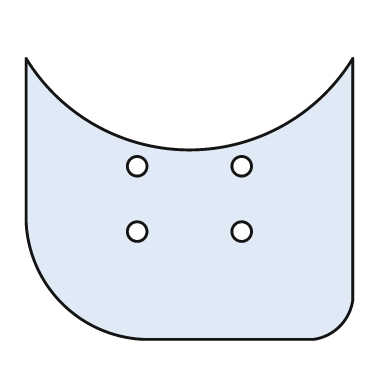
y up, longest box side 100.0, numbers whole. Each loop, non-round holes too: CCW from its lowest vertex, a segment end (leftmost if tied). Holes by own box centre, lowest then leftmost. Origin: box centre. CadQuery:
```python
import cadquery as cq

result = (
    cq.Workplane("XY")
    .moveTo(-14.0, -43.0)
    .lineTo(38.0, -43.0)
    .threePointArc((46.0, -39.0), (50.0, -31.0))
    .lineTo(50.0, 43.0)
    .threePointArc((0.0, 15.0), (-50.0, 43.0))
    .lineTo(-50.0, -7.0)
    .threePointArc((-39.0, -32.0), (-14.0, -43.0))
    .close()
    .moveTo(-16.0, -10.0)
    .circle(3.0)
    .moveTo(16.0, -10.0)
    .circle(3.0)
    .moveTo(-16.0, 10.0)
    .circle(3.0)
    .moveTo(16.0, 10.0)
    .circle(3.0)
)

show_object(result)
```